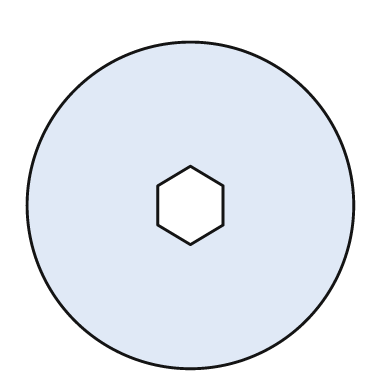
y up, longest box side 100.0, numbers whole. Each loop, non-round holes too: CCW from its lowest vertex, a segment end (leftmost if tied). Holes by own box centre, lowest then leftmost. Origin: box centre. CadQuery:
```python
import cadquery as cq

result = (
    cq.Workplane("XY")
    .moveTo(0.0, 0.0)
    .circle(50.0)
    .moveTo(0.0, -12.0)
    .lineTo(10.0, -6.0)
    .lineTo(10.0, 6.0)
    .lineTo(0.0, 12.0)
    .lineTo(-10.0, 6.0)
    .lineTo(-10.0, -6.0)
    .close()
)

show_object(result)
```